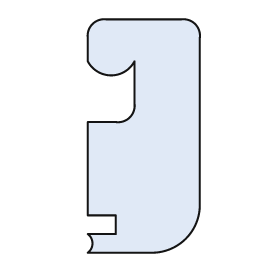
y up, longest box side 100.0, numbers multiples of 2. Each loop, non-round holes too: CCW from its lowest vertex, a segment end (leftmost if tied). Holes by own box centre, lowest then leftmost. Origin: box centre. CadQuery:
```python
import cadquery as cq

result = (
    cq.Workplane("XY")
    .moveTo(-24.0, -50.0)
    .lineTo(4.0, -50.0)
    .threePointArc((18.0, -44.0), (24.0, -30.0))
    .lineTo(24.0, 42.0)
    .threePointArc((22.0, 48.0), (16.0, 50.0))
    .lineTo(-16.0, 50.0)
    .threePointArc((-22.0, 48.0), (-24.0, 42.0))
    .lineTo(-24.0, 32.0)
    .threePointArc((-14.0, 26.0), (-4.0, 32.0))
    .lineTo(-4.0, 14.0)
    .threePointArc((-6.0, 8.0), (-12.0, 6.0))
    .lineTo(-24.0, 6.0)
    .lineTo(-24.0, -34.0)
    .lineTo(-12.0, -34.0)
    .lineTo(-12.0, -42.0)
    .lineTo(-24.0, -42.0)
    .threePointArc((-22.0, -46.0), (-24.0, -50.0))
    .close()
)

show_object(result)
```